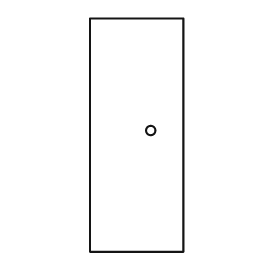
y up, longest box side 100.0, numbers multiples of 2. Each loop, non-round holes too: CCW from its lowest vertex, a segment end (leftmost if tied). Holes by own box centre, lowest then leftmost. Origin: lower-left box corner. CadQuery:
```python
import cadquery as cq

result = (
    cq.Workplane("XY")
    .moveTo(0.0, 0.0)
    .lineTo(40.0, 0.0)
    .lineTo(40.0, 100.0)
    .lineTo(0.0, 100.0)
    .close()
    .moveTo(26.0, 52.0)
    .circle(2.0)
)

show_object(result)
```